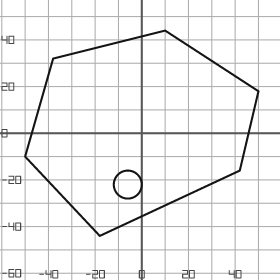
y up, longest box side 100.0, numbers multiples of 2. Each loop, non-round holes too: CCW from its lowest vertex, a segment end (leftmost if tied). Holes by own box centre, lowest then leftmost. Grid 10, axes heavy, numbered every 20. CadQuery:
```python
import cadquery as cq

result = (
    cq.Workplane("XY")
    .moveTo(-18.0, -44.0)
    .lineTo(42.0, -16.0)
    .lineTo(50.0, 18.0)
    .lineTo(10.0, 44.0)
    .lineTo(-38.0, 32.0)
    .lineTo(-50.0, -10.0)
    .close()
    .moveTo(-6.0, -22.0)
    .circle(6.0)
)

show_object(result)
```